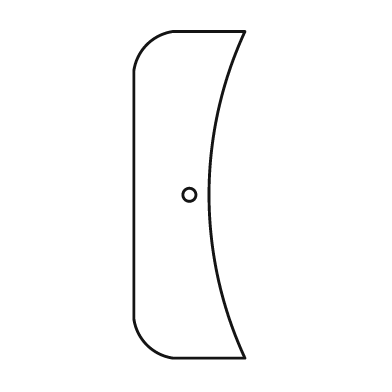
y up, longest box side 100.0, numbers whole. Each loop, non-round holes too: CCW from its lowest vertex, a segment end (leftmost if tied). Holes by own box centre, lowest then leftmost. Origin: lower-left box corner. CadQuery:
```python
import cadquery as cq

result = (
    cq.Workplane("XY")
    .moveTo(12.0, 0.0)
    .lineTo(34.0, 0.0)
    .threePointArc((23.0, 50.0), (34.0, 100.0))
    .lineTo(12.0, 100.0)
    .threePointArc((4.0, 96.0), (0.0, 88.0))
    .lineTo(0.0, 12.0)
    .threePointArc((4.0, 4.0), (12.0, 0.0))
    .close()
    .moveTo(17.0, 50.0)
    .circle(2.0)
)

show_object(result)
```